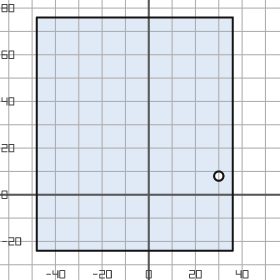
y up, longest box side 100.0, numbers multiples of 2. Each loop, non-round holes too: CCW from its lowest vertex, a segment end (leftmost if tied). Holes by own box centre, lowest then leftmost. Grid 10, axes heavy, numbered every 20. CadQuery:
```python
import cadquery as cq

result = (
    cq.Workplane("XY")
    .moveTo(-48.0, -24.0)
    .lineTo(36.0, -24.0)
    .lineTo(36.0, 76.0)
    .lineTo(-48.0, 76.0)
    .close()
    .moveTo(30.0, 8.0)
    .circle(2.0)
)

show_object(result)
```